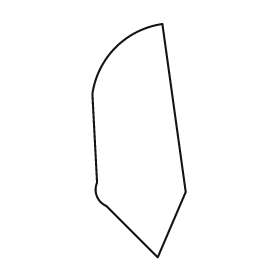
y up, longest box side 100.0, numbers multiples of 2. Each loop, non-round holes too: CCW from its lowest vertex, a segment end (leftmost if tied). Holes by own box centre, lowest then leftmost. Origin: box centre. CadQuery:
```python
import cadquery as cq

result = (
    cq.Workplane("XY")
    .moveTo(8.0, -50.0)
    .lineTo(20.0, -22.0)
    .lineTo(10.0, 50.0)
    .threePointArc((-10.0, 40.0), (-20.0, 20.0))
    .lineTo(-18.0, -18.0)
    .threePointArc((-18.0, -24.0), (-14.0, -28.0))
    .close()
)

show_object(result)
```